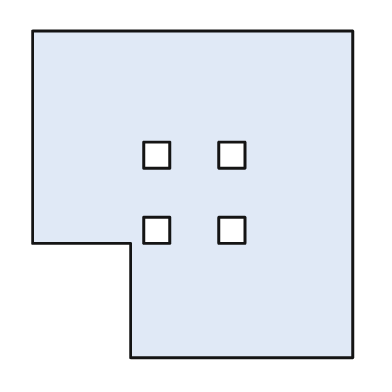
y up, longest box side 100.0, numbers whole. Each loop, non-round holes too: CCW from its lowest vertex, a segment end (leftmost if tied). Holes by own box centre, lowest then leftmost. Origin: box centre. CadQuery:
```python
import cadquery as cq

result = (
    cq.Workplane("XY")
    .moveTo(-19.0, -50.0)
    .lineTo(49.0, -50.0)
    .lineTo(49.0, 50.0)
    .lineTo(-49.0, 50.0)
    .lineTo(-49.0, -15.0)
    .lineTo(-19.0, -15.0)
    .close()
    .moveTo(-15.0, -15.0)
    .lineTo(-7.0, -15.0)
    .lineTo(-7.0, -7.0)
    .lineTo(-15.0, -7.0)
    .close()
    .moveTo(8.0, -15.0)
    .lineTo(16.0, -15.0)
    .lineTo(16.0, -7.0)
    .lineTo(8.0, -7.0)
    .close()
    .moveTo(-15.0, 8.0)
    .lineTo(-7.0, 8.0)
    .lineTo(-7.0, 16.0)
    .lineTo(-15.0, 16.0)
    .close()
    .moveTo(8.0, 8.0)
    .lineTo(16.0, 8.0)
    .lineTo(16.0, 16.0)
    .lineTo(8.0, 16.0)
    .close()
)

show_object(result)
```